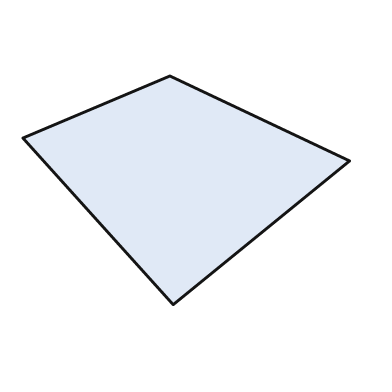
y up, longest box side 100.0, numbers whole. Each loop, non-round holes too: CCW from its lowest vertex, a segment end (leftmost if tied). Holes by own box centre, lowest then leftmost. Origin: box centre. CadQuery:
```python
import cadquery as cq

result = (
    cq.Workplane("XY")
    .moveTo(-4.0, -35.0)
    .lineTo(50.0, 9.0)
    .lineTo(-5.0, 35.0)
    .lineTo(-50.0, 16.0)
    .close()
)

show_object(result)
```